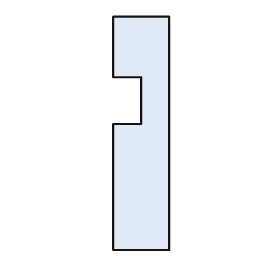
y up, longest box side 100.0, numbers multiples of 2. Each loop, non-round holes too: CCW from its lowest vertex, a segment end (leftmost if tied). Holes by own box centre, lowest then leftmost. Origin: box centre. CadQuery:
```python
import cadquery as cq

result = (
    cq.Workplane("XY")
    .moveTo(-12.0, -50.0)
    .lineTo(12.0, -50.0)
    .lineTo(12.0, 50.0)
    .lineTo(-12.0, 50.0)
    .lineTo(-12.0, 24.0)
    .lineTo(0.0, 24.0)
    .lineTo(0.0, 4.0)
    .lineTo(-12.0, 4.0)
    .close()
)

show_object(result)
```